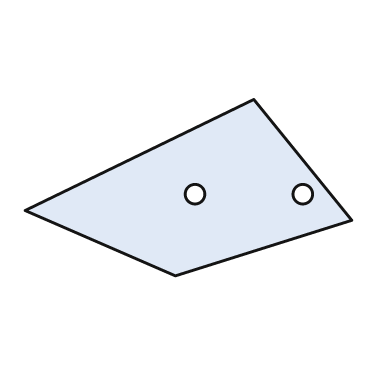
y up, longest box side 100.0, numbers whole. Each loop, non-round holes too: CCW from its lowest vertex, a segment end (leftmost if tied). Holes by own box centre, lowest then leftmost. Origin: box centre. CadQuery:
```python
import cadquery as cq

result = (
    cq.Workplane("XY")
    .moveTo(-4.0, -27.0)
    .lineTo(50.0, -10.0)
    .lineTo(20.0, 27.0)
    .lineTo(-50.0, -7.0)
    .close()
    .moveTo(2.0, -2.0)
    .circle(3.0)
    .moveTo(35.0, -2.0)
    .circle(3.0)
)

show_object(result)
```